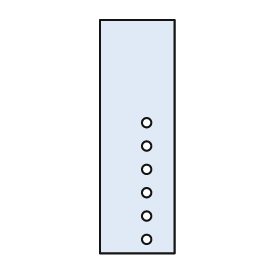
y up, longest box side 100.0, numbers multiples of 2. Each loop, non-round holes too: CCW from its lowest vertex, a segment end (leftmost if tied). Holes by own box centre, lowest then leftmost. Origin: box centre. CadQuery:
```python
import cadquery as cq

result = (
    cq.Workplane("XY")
    .moveTo(-16.0, -50.0)
    .lineTo(16.0, -50.0)
    .lineTo(16.0, 50.0)
    .lineTo(-16.0, 50.0)
    .close()
    .moveTo(4.0, -44.0)
    .circle(2.0)
    .moveTo(4.0, -34.0)
    .circle(2.0)
    .moveTo(4.0, -24.0)
    .circle(2.0)
    .moveTo(4.0, -14.0)
    .circle(2.0)
    .moveTo(4.0, -4.0)
    .circle(2.0)
    .moveTo(4.0, 6.0)
    .circle(2.0)
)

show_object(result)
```